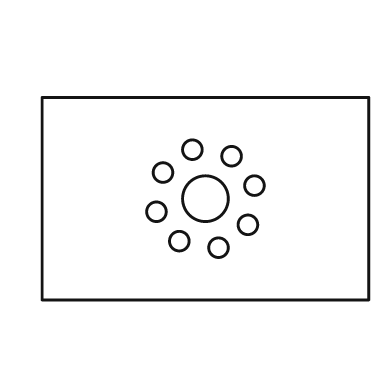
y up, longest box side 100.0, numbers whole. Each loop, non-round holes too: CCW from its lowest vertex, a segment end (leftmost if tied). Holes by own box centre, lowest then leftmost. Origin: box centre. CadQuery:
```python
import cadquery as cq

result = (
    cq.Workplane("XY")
    .moveTo(-50.0, -31.0)
    .lineTo(50.0, -31.0)
    .lineTo(50.0, 31.0)
    .lineTo(-50.0, 31.0)
    .close()
    .moveTo(4.0, -15.0)
    .circle(3.0)
    .moveTo(-8.0, -13.0)
    .circle(3.0)
    .moveTo(13.0, -8.0)
    .circle(3.0)
    .moveTo(-15.0, -4.0)
    .circle(3.0)
    .moveTo(0.0, 0.0)
    .circle(7.0)
    .moveTo(15.0, 4.0)
    .circle(3.0)
    .moveTo(-13.0, 8.0)
    .circle(3.0)
    .moveTo(8.0, 13.0)
    .circle(3.0)
    .moveTo(-4.0, 15.0)
    .circle(3.0)
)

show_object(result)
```